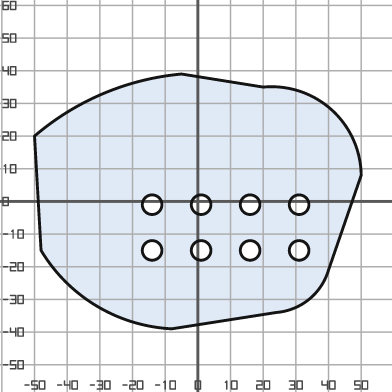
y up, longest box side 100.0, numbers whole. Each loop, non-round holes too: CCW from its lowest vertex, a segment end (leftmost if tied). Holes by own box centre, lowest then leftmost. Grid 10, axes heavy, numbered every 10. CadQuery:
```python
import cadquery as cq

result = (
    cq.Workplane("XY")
    .moveTo(-8.0, -39.0)
    .lineTo(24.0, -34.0)
    .threePointArc((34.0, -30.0), (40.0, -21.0))
    .lineTo(50.0, 8.0)
    .threePointArc((41.0, 28.0), (20.0, 35.0))
    .lineTo(-5.0, 39.0)
    .threePointArc((-29.0, 33.0), (-50.0, 20.0))
    .lineTo(-48.0, -15.0)
    .threePointArc((-31.0, -32.0), (-8.0, -39.0))
    .close()
    .moveTo(-14.0, -15.0)
    .circle(3.0)
    .moveTo(1.0, -15.0)
    .circle(3.0)
    .moveTo(16.0, -15.0)
    .circle(3.0)
    .moveTo(31.0, -15.0)
    .circle(3.0)
    .moveTo(-14.0, -1.0)
    .circle(3.0)
    .moveTo(1.0, -1.0)
    .circle(3.0)
    .moveTo(16.0, -1.0)
    .circle(3.0)
    .moveTo(31.0, -1.0)
    .circle(3.0)
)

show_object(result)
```